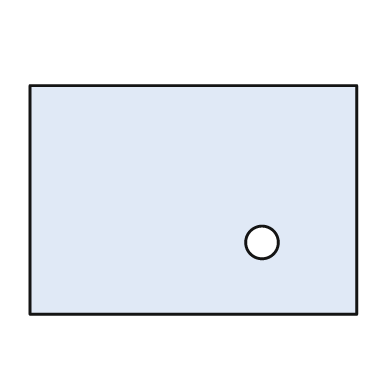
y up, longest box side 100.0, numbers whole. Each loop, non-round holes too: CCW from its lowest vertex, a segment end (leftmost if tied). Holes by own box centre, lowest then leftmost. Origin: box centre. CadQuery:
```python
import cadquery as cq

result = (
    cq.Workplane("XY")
    .moveTo(-50.0, -35.0)
    .lineTo(50.0, -35.0)
    .lineTo(50.0, 35.0)
    .lineTo(-50.0, 35.0)
    .close()
    .moveTo(21.0, -13.0)
    .circle(5.0)
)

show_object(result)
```